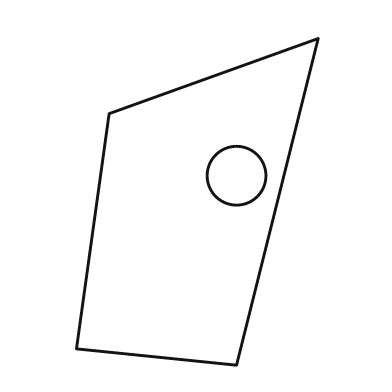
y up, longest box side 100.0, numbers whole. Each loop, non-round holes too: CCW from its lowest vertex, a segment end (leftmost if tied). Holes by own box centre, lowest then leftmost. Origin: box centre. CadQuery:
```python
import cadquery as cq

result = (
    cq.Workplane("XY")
    .moveTo(12.0, -50.0)
    .lineTo(37.0, 50.0)
    .lineTo(-27.0, 27.0)
    .lineTo(-37.0, -45.0)
    .close()
    .moveTo(12.0, 8.0)
    .circle(9.0)
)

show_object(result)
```